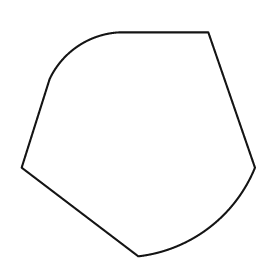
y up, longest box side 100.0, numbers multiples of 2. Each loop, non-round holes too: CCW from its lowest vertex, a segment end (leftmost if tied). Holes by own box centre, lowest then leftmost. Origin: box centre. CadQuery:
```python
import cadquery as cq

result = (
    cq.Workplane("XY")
    .moveTo(0.0, -48.0)
    .threePointArc((30.0, -36.0), (50.0, -10.0))
    .lineTo(30.0, 48.0)
    .lineTo(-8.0, 48.0)
    .threePointArc((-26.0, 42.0), (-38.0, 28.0))
    .lineTo(-50.0, -10.0)
    .close()
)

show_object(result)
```